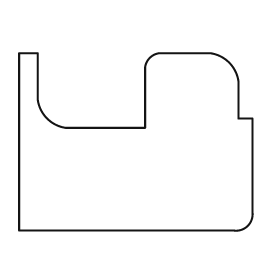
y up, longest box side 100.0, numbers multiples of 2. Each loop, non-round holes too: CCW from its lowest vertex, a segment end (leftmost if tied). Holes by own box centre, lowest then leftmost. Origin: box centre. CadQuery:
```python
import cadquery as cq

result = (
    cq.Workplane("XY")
    .moveTo(-50.0, -38.0)
    .lineTo(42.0, -38.0)
    .threePointArc((48.0, -36.0), (50.0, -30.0))
    .lineTo(50.0, 10.0)
    .lineTo(44.0, 10.0)
    .lineTo(44.0, 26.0)
    .threePointArc((40.0, 34.0), (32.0, 38.0))
    .lineTo(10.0, 38.0)
    .threePointArc((6.0, 36.0), (4.0, 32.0))
    .lineTo(4.0, 6.0)
    .lineTo(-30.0, 6.0)
    .threePointArc((-38.0, 10.0), (-42.0, 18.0))
    .lineTo(-42.0, 38.0)
    .lineTo(-50.0, 38.0)
    .close()
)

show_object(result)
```